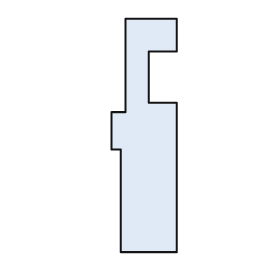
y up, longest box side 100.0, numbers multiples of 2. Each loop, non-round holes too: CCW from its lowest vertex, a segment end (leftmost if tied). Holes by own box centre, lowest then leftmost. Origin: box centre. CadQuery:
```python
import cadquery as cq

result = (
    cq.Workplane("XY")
    .moveTo(-10.0, -50.0)
    .lineTo(14.0, -50.0)
    .lineTo(14.0, 14.0)
    .lineTo(2.0, 14.0)
    .lineTo(2.0, 36.0)
    .lineTo(14.0, 36.0)
    .lineTo(14.0, 50.0)
    .lineTo(-8.0, 50.0)
    .lineTo(-8.0, 10.0)
    .lineTo(-14.0, 10.0)
    .lineTo(-14.0, -6.0)
    .lineTo(-10.0, -6.0)
    .close()
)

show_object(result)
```